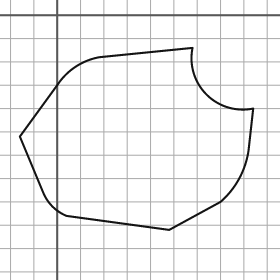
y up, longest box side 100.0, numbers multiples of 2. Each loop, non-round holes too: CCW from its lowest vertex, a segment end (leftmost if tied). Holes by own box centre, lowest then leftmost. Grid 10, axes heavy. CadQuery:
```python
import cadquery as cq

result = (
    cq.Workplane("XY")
    .moveTo(48.0, -92.0)
    .lineTo(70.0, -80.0)
    .threePointArc((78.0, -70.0), (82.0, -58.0))
    .lineTo(84.0, -40.0)
    .threePointArc((64.0, -34.0), (58.0, -14.0))
    .lineTo(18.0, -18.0)
    .threePointArc((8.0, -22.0), (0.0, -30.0))
    .lineTo(-16.0, -52.0)
    .lineTo(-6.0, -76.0)
    .threePointArc((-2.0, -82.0), (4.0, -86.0))
    .close()
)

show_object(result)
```